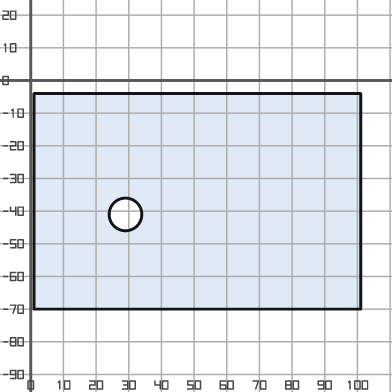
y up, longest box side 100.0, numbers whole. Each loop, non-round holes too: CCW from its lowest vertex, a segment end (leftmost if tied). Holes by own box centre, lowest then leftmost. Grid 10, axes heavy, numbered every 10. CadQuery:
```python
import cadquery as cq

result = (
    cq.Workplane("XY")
    .moveTo(1.0, -70.0)
    .lineTo(101.0, -70.0)
    .lineTo(101.0, -4.0)
    .lineTo(1.0, -4.0)
    .close()
    .moveTo(29.0, -41.0)
    .circle(5.0)
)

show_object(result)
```